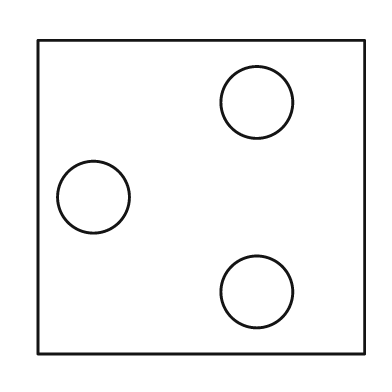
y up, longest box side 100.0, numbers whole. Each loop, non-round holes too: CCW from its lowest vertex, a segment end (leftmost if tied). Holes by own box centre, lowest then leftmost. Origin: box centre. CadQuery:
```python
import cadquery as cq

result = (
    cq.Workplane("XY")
    .moveTo(-50.0, -48.0)
    .lineTo(50.0, -48.0)
    .lineTo(50.0, 48.0)
    .lineTo(-50.0, 48.0)
    .close()
    .moveTo(17.0, -29.0)
    .circle(11.0)
    .moveTo(-33.0, 0.0)
    .circle(11.0)
    .moveTo(17.0, 29.0)
    .circle(11.0)
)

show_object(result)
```